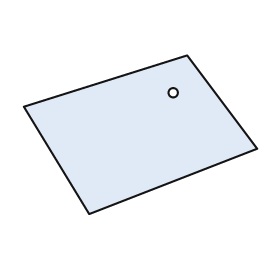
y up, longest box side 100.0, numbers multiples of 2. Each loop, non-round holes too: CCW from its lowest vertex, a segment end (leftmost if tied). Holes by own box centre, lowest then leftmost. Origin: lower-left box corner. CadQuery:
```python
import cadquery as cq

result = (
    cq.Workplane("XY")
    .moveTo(28.0, 0.0)
    .lineTo(100.0, 28.0)
    .lineTo(70.0, 68.0)
    .lineTo(0.0, 46.0)
    .close()
    .moveTo(64.0, 52.0)
    .circle(2.0)
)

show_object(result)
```